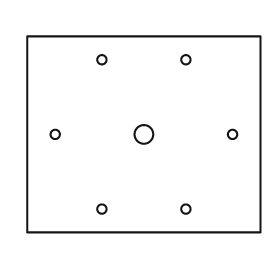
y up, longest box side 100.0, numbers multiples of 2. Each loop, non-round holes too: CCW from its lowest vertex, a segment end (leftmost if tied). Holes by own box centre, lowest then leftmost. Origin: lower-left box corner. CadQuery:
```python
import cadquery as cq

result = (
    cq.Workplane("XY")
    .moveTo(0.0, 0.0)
    .lineTo(100.0, 0.0)
    .lineTo(100.0, 84.0)
    .lineTo(0.0, 84.0)
    .close()
    .moveTo(32.0, 10.0)
    .circle(2.0)
    .moveTo(68.0, 10.0)
    .circle(2.0)
    .moveTo(12.0, 42.0)
    .circle(2.0)
    .moveTo(50.0, 42.0)
    .circle(4.0)
    .moveTo(88.0, 42.0)
    .circle(2.0)
    .moveTo(32.0, 74.0)
    .circle(2.0)
    .moveTo(68.0, 74.0)
    .circle(2.0)
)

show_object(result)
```